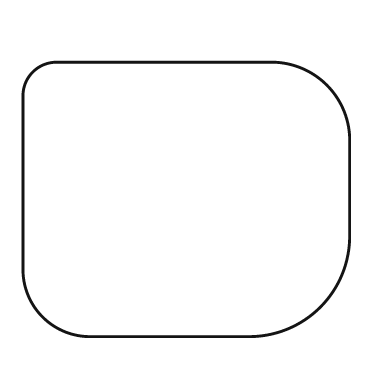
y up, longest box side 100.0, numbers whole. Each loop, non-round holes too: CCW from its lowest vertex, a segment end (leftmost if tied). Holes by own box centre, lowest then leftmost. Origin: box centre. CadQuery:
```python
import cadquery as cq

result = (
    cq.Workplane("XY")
    .moveTo(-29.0, -42.0)
    .lineTo(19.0, -42.0)
    .threePointArc((41.0, -33.0), (50.0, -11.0))
    .lineTo(50.0, 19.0)
    .threePointArc((43.0, 35.0), (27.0, 42.0))
    .lineTo(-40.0, 42.0)
    .threePointArc((-47.0, 39.0), (-50.0, 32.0))
    .lineTo(-50.0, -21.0)
    .threePointArc((-44.0, -36.0), (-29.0, -42.0))
    .close()
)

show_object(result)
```